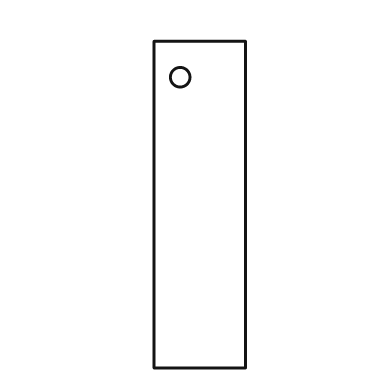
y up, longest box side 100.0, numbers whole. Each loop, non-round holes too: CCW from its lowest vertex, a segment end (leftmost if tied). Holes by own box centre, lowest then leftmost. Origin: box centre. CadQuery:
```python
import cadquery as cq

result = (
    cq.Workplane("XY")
    .moveTo(-14.0, -50.0)
    .lineTo(14.0, -50.0)
    .lineTo(14.0, 50.0)
    .lineTo(-14.0, 50.0)
    .close()
    .moveTo(-6.0, 39.0)
    .circle(3.0)
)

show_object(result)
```